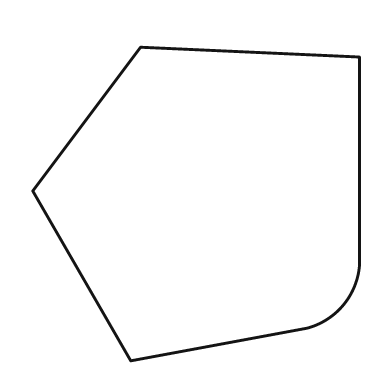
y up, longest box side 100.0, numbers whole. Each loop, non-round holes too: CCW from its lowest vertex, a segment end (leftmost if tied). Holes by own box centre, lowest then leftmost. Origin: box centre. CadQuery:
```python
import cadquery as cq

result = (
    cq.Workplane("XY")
    .moveTo(-20.0, -48.0)
    .lineTo(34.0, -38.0)
    .threePointArc((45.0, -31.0), (50.0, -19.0))
    .lineTo(50.0, 45.0)
    .lineTo(-17.0, 48.0)
    .lineTo(-50.0, 4.0)
    .close()
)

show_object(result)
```